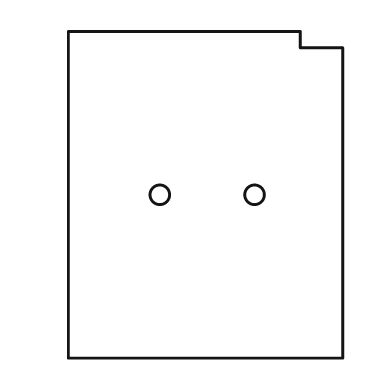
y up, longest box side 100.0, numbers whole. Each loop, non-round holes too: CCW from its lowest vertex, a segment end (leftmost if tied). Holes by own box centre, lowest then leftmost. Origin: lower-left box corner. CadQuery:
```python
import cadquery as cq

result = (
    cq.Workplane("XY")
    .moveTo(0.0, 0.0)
    .lineTo(84.0, 0.0)
    .lineTo(84.0, 95.0)
    .lineTo(71.0, 95.0)
    .lineTo(71.0, 100.0)
    .lineTo(0.0, 100.0)
    .close()
    .moveTo(28.0, 50.0)
    .circle(3.0)
    .moveTo(57.0, 50.0)
    .circle(3.0)
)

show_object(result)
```